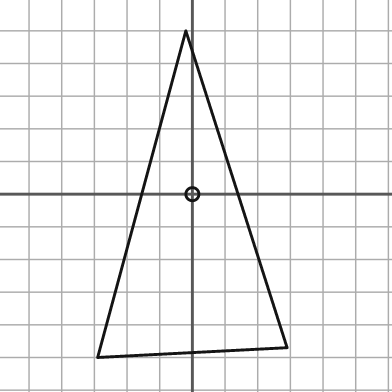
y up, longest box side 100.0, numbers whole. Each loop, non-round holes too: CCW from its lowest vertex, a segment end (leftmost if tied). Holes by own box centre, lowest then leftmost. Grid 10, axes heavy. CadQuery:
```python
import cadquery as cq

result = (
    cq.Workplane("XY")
    .moveTo(-29.0, -50.0)
    .lineTo(29.0, -47.0)
    .lineTo(-2.0, 50.0)
    .close()
    .moveTo(0.0, 0.0)
    .circle(2.0)
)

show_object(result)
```